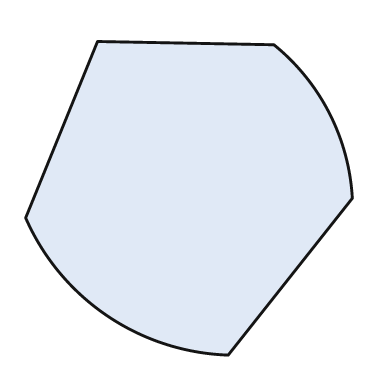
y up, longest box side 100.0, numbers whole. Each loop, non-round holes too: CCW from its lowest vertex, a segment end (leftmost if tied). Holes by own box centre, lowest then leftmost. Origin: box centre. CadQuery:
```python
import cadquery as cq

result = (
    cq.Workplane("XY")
    .moveTo(12.0, -48.0)
    .lineTo(50.0, 0.0)
    .threePointArc((43.0, 26.0), (26.0, 47.0))
    .lineTo(-28.0, 48.0)
    .lineTo(-50.0, -6.0)
    .threePointArc((-25.0, -36.0), (12.0, -48.0))
    .close()
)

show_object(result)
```